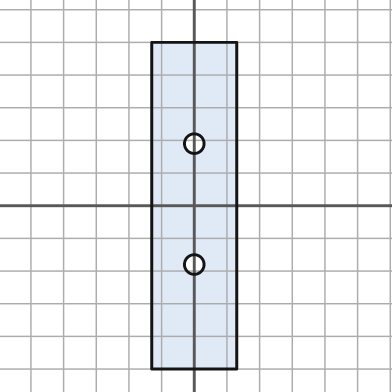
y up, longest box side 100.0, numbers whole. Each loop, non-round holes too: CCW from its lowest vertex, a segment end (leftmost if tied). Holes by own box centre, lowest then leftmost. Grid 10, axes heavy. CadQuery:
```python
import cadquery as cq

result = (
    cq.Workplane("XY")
    .moveTo(-13.0, -50.0)
    .lineTo(13.0, -50.0)
    .lineTo(13.0, 50.0)
    .lineTo(-13.0, 50.0)
    .close()
    .moveTo(0.0, -18.0)
    .circle(3.0)
    .moveTo(0.0, 19.0)
    .circle(3.0)
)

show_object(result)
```